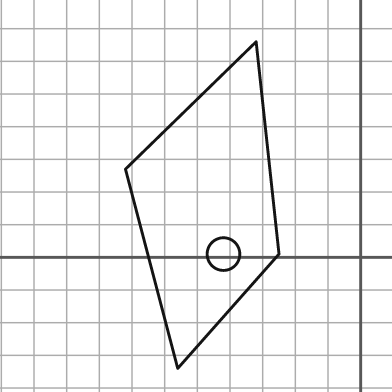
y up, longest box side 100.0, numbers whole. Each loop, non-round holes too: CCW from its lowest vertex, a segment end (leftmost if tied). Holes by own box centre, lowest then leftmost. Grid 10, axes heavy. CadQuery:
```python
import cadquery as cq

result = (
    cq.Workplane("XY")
    .moveTo(-56.0, -34.0)
    .lineTo(-25.0, 1.0)
    .lineTo(-32.0, 66.0)
    .lineTo(-72.0, 27.0)
    .close()
    .moveTo(-42.0, 1.0)
    .circle(5.0)
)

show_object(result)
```